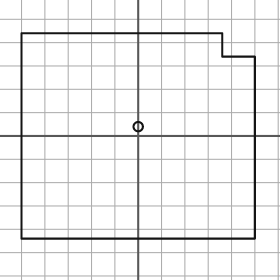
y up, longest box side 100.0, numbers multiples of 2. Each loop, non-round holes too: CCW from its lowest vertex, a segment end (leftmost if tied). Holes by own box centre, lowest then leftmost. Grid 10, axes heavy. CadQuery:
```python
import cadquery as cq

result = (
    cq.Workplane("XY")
    .moveTo(-50.0, -44.0)
    .lineTo(50.0, -44.0)
    .lineTo(50.0, 34.0)
    .lineTo(36.0, 34.0)
    .lineTo(36.0, 44.0)
    .lineTo(-50.0, 44.0)
    .close()
    .moveTo(0.0, 4.0)
    .circle(2.0)
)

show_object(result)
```